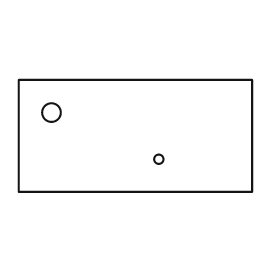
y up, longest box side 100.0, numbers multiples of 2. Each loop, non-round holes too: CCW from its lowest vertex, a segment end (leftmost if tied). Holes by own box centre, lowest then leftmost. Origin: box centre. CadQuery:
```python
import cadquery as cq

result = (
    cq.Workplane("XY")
    .moveTo(-50.0, -24.0)
    .lineTo(50.0, -24.0)
    .lineTo(50.0, 24.0)
    .lineTo(-50.0, 24.0)
    .close()
    .moveTo(10.0, -10.0)
    .circle(2.0)
    .moveTo(-36.0, 10.0)
    .circle(4.0)
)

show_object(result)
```